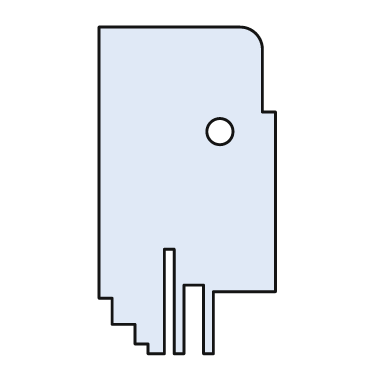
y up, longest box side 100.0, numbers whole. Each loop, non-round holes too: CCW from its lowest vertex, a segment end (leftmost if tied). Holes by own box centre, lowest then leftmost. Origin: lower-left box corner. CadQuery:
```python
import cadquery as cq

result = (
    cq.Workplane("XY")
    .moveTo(15.0, 0.0)
    .lineTo(20.0, 0.0)
    .lineTo(20.0, 32.0)
    .lineTo(23.0, 32.0)
    .lineTo(23.0, 0.0)
    .lineTo(26.0, 0.0)
    .lineTo(26.0, 21.0)
    .lineTo(32.0, 21.0)
    .lineTo(32.0, 0.0)
    .lineTo(35.0, 0.0)
    .lineTo(35.0, 19.0)
    .lineTo(54.0, 19.0)
    .lineTo(54.0, 74.0)
    .lineTo(50.0, 74.0)
    .lineTo(50.0, 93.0)
    .threePointArc((48.0, 98.0), (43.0, 100.0))
    .lineTo(0.0, 100.0)
    .lineTo(0.0, 17.0)
    .lineTo(4.0, 17.0)
    .lineTo(4.0, 9.0)
    .lineTo(11.0, 9.0)
    .lineTo(11.0, 3.0)
    .lineTo(15.0, 3.0)
    .close()
    .moveTo(37.0, 68.0)
    .circle(4.0)
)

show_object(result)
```